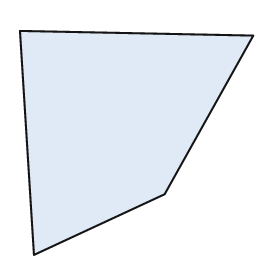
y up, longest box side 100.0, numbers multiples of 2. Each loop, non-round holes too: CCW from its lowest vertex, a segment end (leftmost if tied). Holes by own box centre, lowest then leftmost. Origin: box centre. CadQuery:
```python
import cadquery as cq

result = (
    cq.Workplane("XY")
    .moveTo(-44.0, -48.0)
    .lineTo(12.0, -22.0)
    .lineTo(50.0, 46.0)
    .lineTo(-50.0, 48.0)
    .close()
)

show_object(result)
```